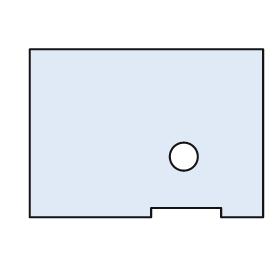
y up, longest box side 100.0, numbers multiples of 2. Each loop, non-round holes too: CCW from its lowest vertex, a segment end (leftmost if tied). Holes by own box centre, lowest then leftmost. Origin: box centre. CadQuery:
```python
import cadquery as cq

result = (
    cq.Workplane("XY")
    .moveTo(-50.0, -36.0)
    .lineTo(2.0, -36.0)
    .lineTo(2.0, -32.0)
    .lineTo(32.0, -32.0)
    .lineTo(32.0, -36.0)
    .lineTo(50.0, -36.0)
    .lineTo(50.0, 36.0)
    .lineTo(-50.0, 36.0)
    .close()
    .moveTo(16.0, -10.0)
    .circle(6.0)
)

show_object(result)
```